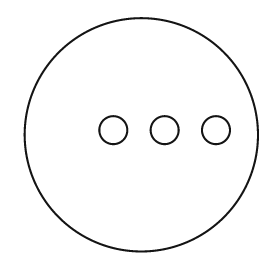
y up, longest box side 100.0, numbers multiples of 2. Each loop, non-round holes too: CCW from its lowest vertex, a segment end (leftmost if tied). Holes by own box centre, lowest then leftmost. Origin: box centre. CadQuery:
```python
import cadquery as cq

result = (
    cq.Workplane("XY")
    .moveTo(0.0, 0.0)
    .circle(50.0)
    .moveTo(-12.0, 2.0)
    .circle(6.0)
    .moveTo(10.0, 2.0)
    .circle(6.0)
    .moveTo(32.0, 2.0)
    .circle(6.0)
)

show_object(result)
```